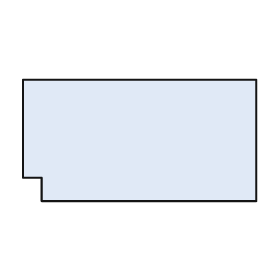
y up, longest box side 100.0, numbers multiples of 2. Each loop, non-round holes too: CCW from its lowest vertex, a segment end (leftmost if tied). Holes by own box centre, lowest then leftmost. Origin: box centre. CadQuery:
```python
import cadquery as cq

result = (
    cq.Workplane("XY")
    .moveTo(-42.0, -26.0)
    .lineTo(50.0, -26.0)
    .lineTo(50.0, 26.0)
    .lineTo(-50.0, 26.0)
    .lineTo(-50.0, -16.0)
    .lineTo(-42.0, -16.0)
    .close()
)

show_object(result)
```